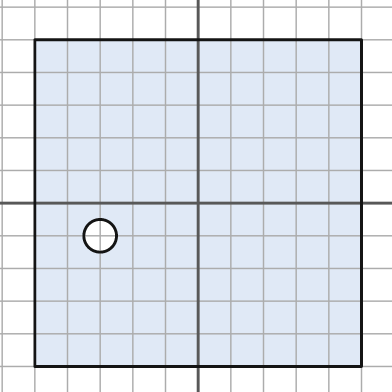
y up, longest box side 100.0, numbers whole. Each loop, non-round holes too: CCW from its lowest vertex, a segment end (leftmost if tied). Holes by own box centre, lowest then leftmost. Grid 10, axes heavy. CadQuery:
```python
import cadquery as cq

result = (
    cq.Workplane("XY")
    .moveTo(-50.0, -50.0)
    .lineTo(50.0, -50.0)
    .lineTo(50.0, 50.0)
    .lineTo(-50.0, 50.0)
    .close()
    .moveTo(-30.0, -10.0)
    .circle(5.0)
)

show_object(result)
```